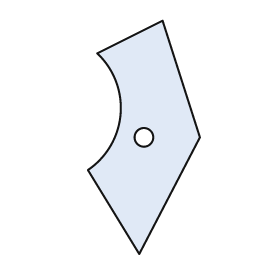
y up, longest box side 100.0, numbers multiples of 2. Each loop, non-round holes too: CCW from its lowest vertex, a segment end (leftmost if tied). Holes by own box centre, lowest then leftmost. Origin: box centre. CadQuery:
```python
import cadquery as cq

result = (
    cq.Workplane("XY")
    .moveTo(-2.0, -50.0)
    .lineTo(24.0, 0.0)
    .lineTo(8.0, 50.0)
    .lineTo(-20.0, 36.0)
    .threePointArc((-10.0, 10.0), (-24.0, -14.0))
    .close()
    .moveTo(0.0, 0.0)
    .circle(4.0)
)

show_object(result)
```